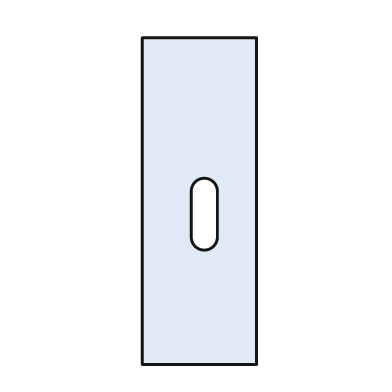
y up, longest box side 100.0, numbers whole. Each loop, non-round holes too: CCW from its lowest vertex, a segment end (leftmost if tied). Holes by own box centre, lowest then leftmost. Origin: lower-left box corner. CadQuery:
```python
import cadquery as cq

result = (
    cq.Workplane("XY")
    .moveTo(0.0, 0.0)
    .lineTo(35.0, 0.0)
    .lineTo(35.0, 100.0)
    .lineTo(0.0, 100.0)
    .close()
    .moveTo(15.0, 39.0)
    .threePointArc((19.0, 35.0), (23.0, 39.0))
    .lineTo(23.0, 53.0)
    .threePointArc((19.0, 57.0), (15.0, 53.0))
    .close()
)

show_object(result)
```